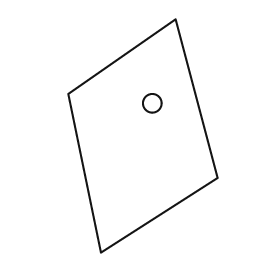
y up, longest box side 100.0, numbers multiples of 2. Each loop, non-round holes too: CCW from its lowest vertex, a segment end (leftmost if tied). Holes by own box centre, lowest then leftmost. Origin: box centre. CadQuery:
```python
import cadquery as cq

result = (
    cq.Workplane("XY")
    .moveTo(-18.0, -50.0)
    .lineTo(32.0, -18.0)
    .lineTo(14.0, 50.0)
    .lineTo(-32.0, 18.0)
    .close()
    .moveTo(4.0, 14.0)
    .circle(4.0)
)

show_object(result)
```